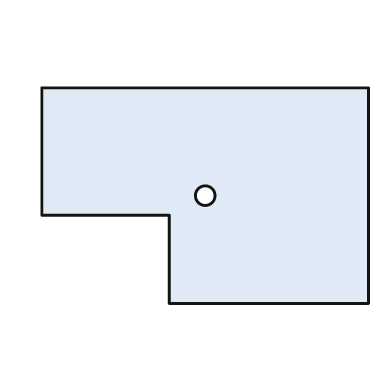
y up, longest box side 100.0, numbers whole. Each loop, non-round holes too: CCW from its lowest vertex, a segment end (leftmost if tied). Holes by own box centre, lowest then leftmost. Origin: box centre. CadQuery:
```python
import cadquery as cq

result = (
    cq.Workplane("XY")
    .moveTo(-11.0, -33.0)
    .lineTo(50.0, -33.0)
    .lineTo(50.0, 33.0)
    .lineTo(-50.0, 33.0)
    .lineTo(-50.0, -6.0)
    .lineTo(-11.0, -6.0)
    .close()
    .moveTo(0.0, 0.0)
    .circle(3.0)
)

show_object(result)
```